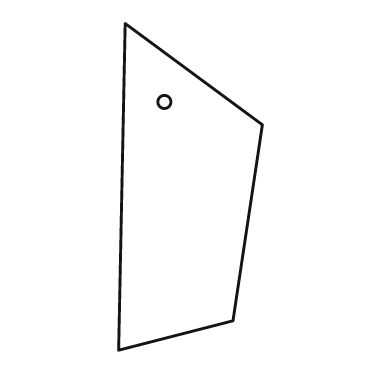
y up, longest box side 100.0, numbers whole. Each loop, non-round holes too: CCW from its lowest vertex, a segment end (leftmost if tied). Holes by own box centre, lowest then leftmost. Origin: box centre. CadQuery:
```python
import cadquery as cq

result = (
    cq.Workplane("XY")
    .moveTo(-22.0, -50.0)
    .lineTo(13.0, -41.0)
    .lineTo(22.0, 19.0)
    .lineTo(-20.0, 50.0)
    .close()
    .moveTo(-8.0, 26.0)
    .circle(2.0)
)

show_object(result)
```